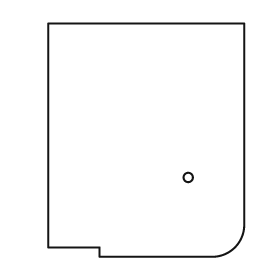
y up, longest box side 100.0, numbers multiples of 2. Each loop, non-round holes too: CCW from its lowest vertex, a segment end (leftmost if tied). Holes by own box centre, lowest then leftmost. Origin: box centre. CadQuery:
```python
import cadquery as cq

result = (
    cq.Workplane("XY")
    .moveTo(-20.0, -50.0)
    .lineTo(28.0, -50.0)
    .threePointArc((38.0, -46.0), (42.0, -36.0))
    .lineTo(42.0, 50.0)
    .lineTo(-42.0, 50.0)
    .lineTo(-42.0, -46.0)
    .lineTo(-20.0, -46.0)
    .close()
    .moveTo(18.0, -16.0)
    .circle(2.0)
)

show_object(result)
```